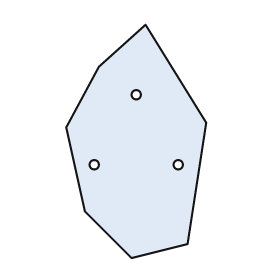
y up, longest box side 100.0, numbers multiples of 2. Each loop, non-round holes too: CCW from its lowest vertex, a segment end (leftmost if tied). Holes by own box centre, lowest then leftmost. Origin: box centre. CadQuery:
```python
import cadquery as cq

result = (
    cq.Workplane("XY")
    .moveTo(-2.0, -50.0)
    .lineTo(22.0, -44.0)
    .lineTo(30.0, 8.0)
    .lineTo(4.0, 50.0)
    .lineTo(-16.0, 32.0)
    .lineTo(-30.0, 6.0)
    .lineTo(-22.0, -30.0)
    .close()
    .moveTo(-18.0, -10.0)
    .circle(2.0)
    .moveTo(18.0, -10.0)
    .circle(2.0)
    .moveTo(0.0, 20.0)
    .circle(2.0)
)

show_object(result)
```